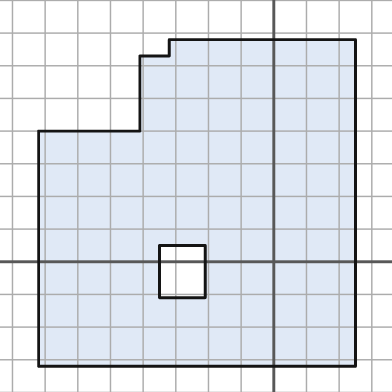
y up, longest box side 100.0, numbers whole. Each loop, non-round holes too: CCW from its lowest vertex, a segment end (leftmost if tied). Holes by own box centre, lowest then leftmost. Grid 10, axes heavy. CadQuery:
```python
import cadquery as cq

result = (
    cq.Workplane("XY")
    .moveTo(-72.0, -32.0)
    .lineTo(25.0, -32.0)
    .lineTo(25.0, 68.0)
    .lineTo(-32.0, 68.0)
    .lineTo(-32.0, 63.0)
    .lineTo(-41.0, 63.0)
    .lineTo(-41.0, 40.0)
    .lineTo(-72.0, 40.0)
    .close()
    .moveTo(-35.0, -11.0)
    .lineTo(-21.0, -11.0)
    .lineTo(-21.0, 5.0)
    .lineTo(-35.0, 5.0)
    .close()
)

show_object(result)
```